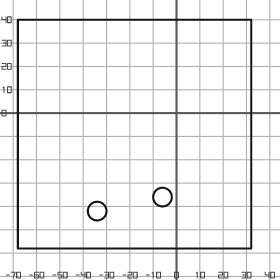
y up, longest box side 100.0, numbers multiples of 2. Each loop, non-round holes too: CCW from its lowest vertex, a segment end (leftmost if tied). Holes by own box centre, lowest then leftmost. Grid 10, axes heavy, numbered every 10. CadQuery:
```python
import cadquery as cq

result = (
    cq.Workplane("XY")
    .moveTo(-68.0, -58.0)
    .lineTo(32.0, -58.0)
    .lineTo(32.0, 40.0)
    .lineTo(-68.0, 40.0)
    .close()
    .moveTo(-34.0, -42.0)
    .circle(4.0)
    .moveTo(-6.0, -36.0)
    .circle(4.0)
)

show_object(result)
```